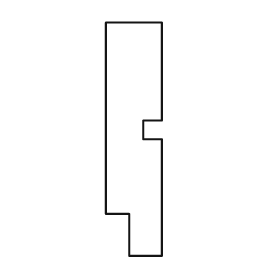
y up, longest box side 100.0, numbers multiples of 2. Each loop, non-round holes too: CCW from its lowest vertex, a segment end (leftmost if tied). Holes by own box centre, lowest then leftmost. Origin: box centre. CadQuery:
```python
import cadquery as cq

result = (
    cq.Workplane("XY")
    .moveTo(-2.0, -50.0)
    .lineTo(12.0, -50.0)
    .lineTo(12.0, 0.0)
    .lineTo(4.0, 0.0)
    .lineTo(4.0, 8.0)
    .lineTo(12.0, 8.0)
    .lineTo(12.0, 50.0)
    .lineTo(-12.0, 50.0)
    .lineTo(-12.0, -32.0)
    .lineTo(-2.0, -32.0)
    .close()
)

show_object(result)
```